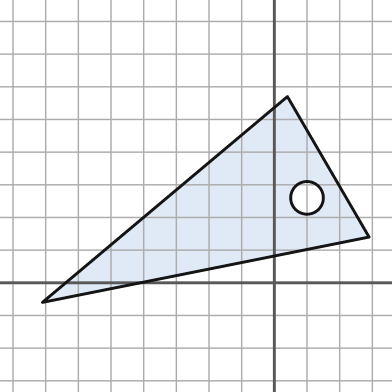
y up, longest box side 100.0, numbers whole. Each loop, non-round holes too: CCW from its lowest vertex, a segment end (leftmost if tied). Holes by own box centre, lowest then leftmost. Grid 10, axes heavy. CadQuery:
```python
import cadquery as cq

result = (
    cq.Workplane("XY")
    .moveTo(-71.0, -6.0)
    .lineTo(29.0, 14.0)
    .lineTo(4.0, 57.0)
    .close()
    .moveTo(10.0, 26.0)
    .circle(5.0)
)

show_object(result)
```